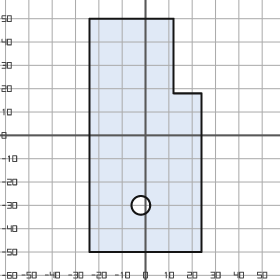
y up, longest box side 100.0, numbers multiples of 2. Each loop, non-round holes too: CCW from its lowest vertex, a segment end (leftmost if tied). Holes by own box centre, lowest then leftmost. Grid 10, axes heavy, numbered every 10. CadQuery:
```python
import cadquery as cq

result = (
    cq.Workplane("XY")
    .moveTo(-24.0, -50.0)
    .lineTo(24.0, -50.0)
    .lineTo(24.0, 18.0)
    .lineTo(12.0, 18.0)
    .lineTo(12.0, 50.0)
    .lineTo(-24.0, 50.0)
    .close()
    .moveTo(-2.0, -30.0)
    .circle(4.0)
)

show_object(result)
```